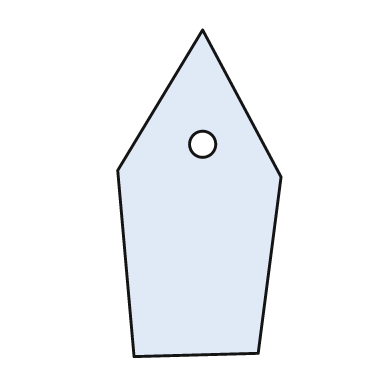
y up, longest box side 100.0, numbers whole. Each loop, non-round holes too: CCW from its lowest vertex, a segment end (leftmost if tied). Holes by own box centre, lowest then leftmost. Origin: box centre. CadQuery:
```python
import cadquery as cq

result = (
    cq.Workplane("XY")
    .moveTo(-20.0, -50.0)
    .lineTo(18.0, -49.0)
    .lineTo(25.0, 5.0)
    .lineTo(1.0, 50.0)
    .lineTo(-25.0, 7.0)
    .close()
    .moveTo(1.0, 15.0)
    .circle(4.0)
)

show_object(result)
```